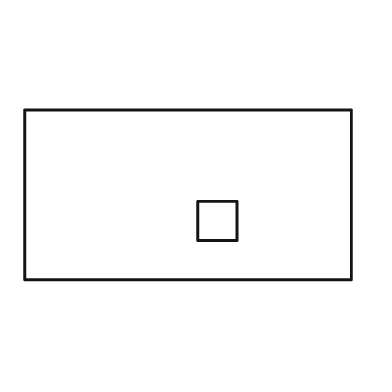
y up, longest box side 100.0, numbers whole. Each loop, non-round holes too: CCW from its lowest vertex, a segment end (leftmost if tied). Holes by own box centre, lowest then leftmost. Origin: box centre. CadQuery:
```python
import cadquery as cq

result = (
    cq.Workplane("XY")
    .moveTo(-50.0, -26.0)
    .lineTo(50.0, -26.0)
    .lineTo(50.0, 26.0)
    .lineTo(-50.0, 26.0)
    .close()
    .moveTo(3.0, -14.0)
    .lineTo(15.0, -14.0)
    .lineTo(15.0, -2.0)
    .lineTo(3.0, -2.0)
    .close()
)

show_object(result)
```